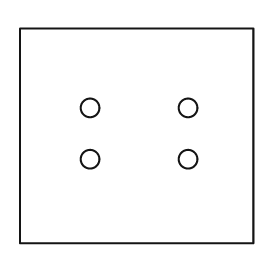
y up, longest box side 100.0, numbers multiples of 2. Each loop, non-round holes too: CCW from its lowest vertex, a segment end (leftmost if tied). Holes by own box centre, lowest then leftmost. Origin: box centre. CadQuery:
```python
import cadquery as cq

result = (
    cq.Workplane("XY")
    .moveTo(-50.0, -46.0)
    .lineTo(50.0, -46.0)
    .lineTo(50.0, 46.0)
    .lineTo(-50.0, 46.0)
    .close()
    .moveTo(-20.0, -10.0)
    .circle(4.0)
    .moveTo(22.0, -10.0)
    .circle(4.0)
    .moveTo(-20.0, 12.0)
    .circle(4.0)
    .moveTo(22.0, 12.0)
    .circle(4.0)
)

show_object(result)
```